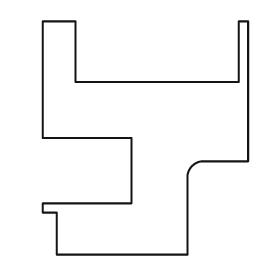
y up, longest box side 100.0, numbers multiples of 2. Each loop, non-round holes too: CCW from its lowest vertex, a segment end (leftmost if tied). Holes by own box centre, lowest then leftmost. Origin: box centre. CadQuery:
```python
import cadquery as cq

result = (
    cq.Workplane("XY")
    .moveTo(-38.0, -50.0)
    .lineTo(18.0, -50.0)
    .lineTo(18.0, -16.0)
    .threePointArc((20.0, -12.0), (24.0, -10.0))
    .lineTo(44.0, -10.0)
    .lineTo(44.0, 50.0)
    .lineTo(40.0, 50.0)
    .lineTo(40.0, 24.0)
    .lineTo(-30.0, 24.0)
    .lineTo(-30.0, 50.0)
    .lineTo(-44.0, 50.0)
    .lineTo(-44.0, 0.0)
    .lineTo(-6.0, 0.0)
    .lineTo(-6.0, -28.0)
    .lineTo(-44.0, -28.0)
    .lineTo(-44.0, -32.0)
    .lineTo(-38.0, -32.0)
    .close()
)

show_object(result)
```